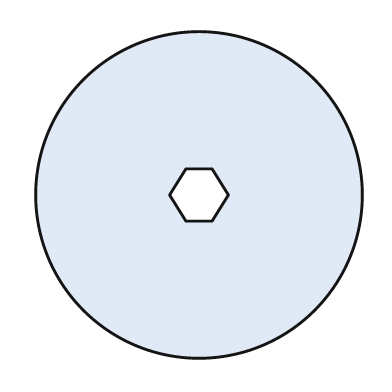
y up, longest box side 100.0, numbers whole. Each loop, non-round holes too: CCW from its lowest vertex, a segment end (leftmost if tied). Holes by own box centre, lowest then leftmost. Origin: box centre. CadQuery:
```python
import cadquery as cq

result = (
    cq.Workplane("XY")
    .moveTo(0.0, 0.0)
    .circle(50.0)
    .moveTo(-4.0, -8.0)
    .lineTo(4.0, -8.0)
    .lineTo(9.0, 0.0)
    .lineTo(4.0, 8.0)
    .lineTo(-4.0, 8.0)
    .lineTo(-9.0, 0.0)
    .close()
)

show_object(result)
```